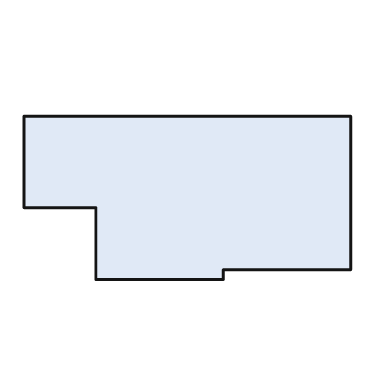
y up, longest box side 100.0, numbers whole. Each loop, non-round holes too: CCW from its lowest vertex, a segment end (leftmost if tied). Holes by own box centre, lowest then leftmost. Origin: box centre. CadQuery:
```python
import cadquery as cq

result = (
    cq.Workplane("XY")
    .moveTo(-28.0, -25.0)
    .lineTo(11.0, -25.0)
    .lineTo(11.0, -22.0)
    .lineTo(50.0, -22.0)
    .lineTo(50.0, 25.0)
    .lineTo(-50.0, 25.0)
    .lineTo(-50.0, -3.0)
    .lineTo(-28.0, -3.0)
    .close()
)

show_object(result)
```